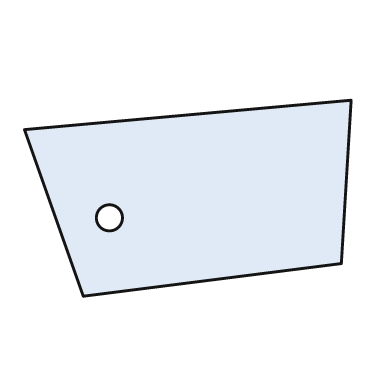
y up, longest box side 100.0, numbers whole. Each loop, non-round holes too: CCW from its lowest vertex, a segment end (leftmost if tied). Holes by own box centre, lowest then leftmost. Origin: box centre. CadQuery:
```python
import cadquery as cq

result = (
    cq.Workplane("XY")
    .moveTo(-32.0, -30.0)
    .lineTo(47.0, -20.0)
    .lineTo(50.0, 30.0)
    .lineTo(-50.0, 21.0)
    .close()
    .moveTo(-24.0, -6.0)
    .circle(4.0)
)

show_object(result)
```